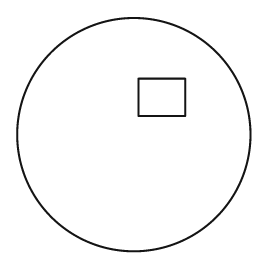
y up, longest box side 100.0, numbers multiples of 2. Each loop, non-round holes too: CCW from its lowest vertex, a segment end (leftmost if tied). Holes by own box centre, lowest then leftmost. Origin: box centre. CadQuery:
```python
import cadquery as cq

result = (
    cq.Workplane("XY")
    .moveTo(0.0, 0.0)
    .circle(50.0)
    .moveTo(2.0, 8.0)
    .lineTo(22.0, 8.0)
    .lineTo(22.0, 24.0)
    .lineTo(2.0, 24.0)
    .close()
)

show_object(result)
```